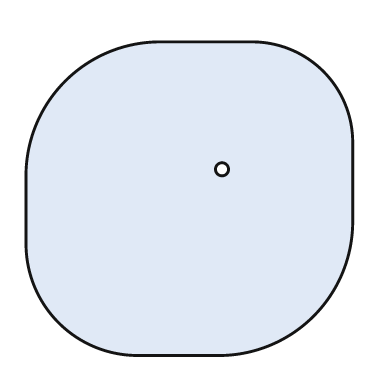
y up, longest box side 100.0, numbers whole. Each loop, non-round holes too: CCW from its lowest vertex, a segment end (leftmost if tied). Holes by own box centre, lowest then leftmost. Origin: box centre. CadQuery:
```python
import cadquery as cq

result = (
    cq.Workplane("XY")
    .moveTo(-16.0, -48.0)
    .lineTo(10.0, -48.0)
    .threePointArc((38.0, -36.0), (50.0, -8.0))
    .lineTo(50.0, 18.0)
    .threePointArc((41.0, 39.0), (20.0, 48.0))
    .lineTo(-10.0, 48.0)
    .threePointArc((-38.0, 36.0), (-50.0, 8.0))
    .lineTo(-50.0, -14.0)
    .threePointArc((-40.0, -38.0), (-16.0, -48.0))
    .close()
    .moveTo(10.0, 9.0)
    .circle(2.0)
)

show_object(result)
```